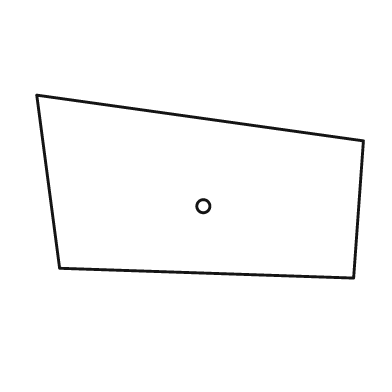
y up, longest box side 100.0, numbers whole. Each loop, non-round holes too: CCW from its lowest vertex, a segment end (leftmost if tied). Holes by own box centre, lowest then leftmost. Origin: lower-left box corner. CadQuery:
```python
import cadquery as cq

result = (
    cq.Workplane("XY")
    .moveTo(97.0, 0.0)
    .lineTo(100.0, 42.0)
    .lineTo(0.0, 56.0)
    .lineTo(7.0, 3.0)
    .close()
    .moveTo(51.0, 22.0)
    .circle(2.0)
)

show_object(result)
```